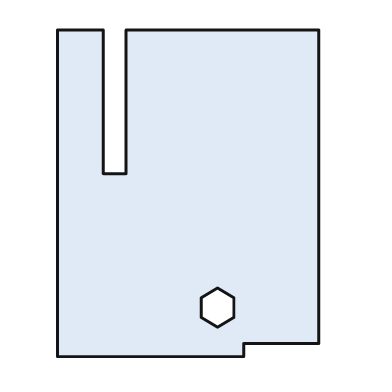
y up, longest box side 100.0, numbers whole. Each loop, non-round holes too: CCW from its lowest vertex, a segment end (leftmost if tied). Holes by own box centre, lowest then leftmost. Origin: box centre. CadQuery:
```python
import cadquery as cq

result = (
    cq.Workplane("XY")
    .moveTo(-40.0, -50.0)
    .lineTo(17.0, -50.0)
    .lineTo(17.0, -46.0)
    .lineTo(40.0, -46.0)
    .lineTo(40.0, 50.0)
    .lineTo(-19.0, 50.0)
    .lineTo(-19.0, 6.0)
    .lineTo(-26.0, 6.0)
    .lineTo(-26.0, 50.0)
    .lineTo(-40.0, 50.0)
    .close()
    .moveTo(9.0, -41.0)
    .lineTo(14.0, -38.0)
    .lineTo(14.0, -32.0)
    .lineTo(9.0, -29.0)
    .lineTo(4.0, -32.0)
    .lineTo(4.0, -38.0)
    .close()
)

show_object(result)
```